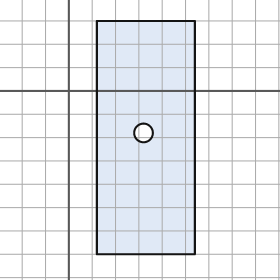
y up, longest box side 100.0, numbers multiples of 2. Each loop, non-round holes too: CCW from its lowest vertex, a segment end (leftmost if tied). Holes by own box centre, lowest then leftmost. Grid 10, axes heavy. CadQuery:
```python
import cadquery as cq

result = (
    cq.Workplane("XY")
    .moveTo(12.0, -70.0)
    .lineTo(54.0, -70.0)
    .lineTo(54.0, 30.0)
    .lineTo(12.0, 30.0)
    .close()
    .moveTo(32.0, -18.0)
    .circle(4.0)
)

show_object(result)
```